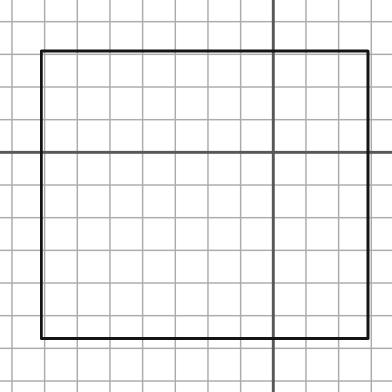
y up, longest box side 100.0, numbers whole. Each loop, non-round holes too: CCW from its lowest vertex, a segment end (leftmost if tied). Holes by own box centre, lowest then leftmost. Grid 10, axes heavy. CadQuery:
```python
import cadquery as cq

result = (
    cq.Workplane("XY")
    .moveTo(-71.0, -57.0)
    .lineTo(29.0, -57.0)
    .lineTo(29.0, 31.0)
    .lineTo(-71.0, 31.0)
    .close()
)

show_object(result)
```